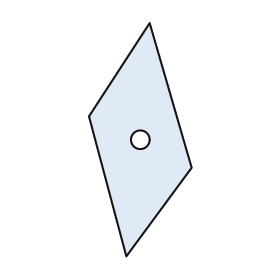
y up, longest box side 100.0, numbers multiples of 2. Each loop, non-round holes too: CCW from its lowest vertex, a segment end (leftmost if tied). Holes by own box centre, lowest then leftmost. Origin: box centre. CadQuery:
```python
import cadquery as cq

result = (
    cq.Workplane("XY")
    .moveTo(-6.0, -50.0)
    .lineTo(22.0, -12.0)
    .lineTo(4.0, 50.0)
    .lineTo(-22.0, 10.0)
    .close()
    .moveTo(0.0, 0.0)
    .circle(4.0)
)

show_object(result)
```